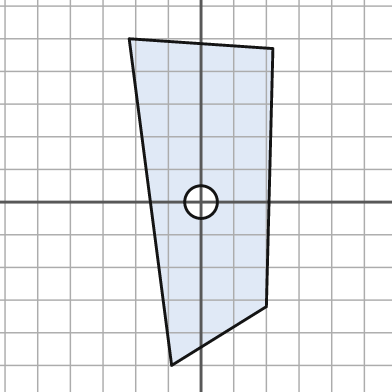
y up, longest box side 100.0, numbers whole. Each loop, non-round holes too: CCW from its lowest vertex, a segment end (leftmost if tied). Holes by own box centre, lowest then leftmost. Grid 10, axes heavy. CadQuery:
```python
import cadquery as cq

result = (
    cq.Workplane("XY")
    .moveTo(-9.0, -50.0)
    .lineTo(20.0, -32.0)
    .lineTo(22.0, 47.0)
    .lineTo(-22.0, 50.0)
    .close()
    .moveTo(0.0, 0.0)
    .circle(5.0)
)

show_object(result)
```